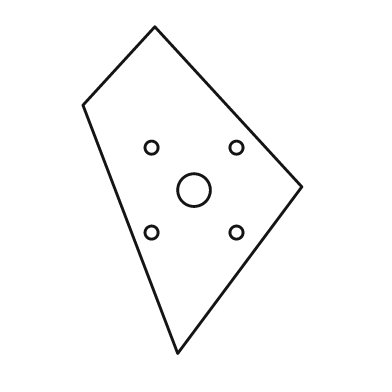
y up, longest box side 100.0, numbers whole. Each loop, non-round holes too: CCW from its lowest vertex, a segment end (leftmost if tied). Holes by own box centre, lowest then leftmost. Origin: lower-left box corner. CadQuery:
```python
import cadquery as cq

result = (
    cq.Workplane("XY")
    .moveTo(29.0, 0.0)
    .lineTo(67.0, 51.0)
    .lineTo(22.0, 100.0)
    .lineTo(0.0, 76.0)
    .close()
    .moveTo(21.0, 37.0)
    .circle(2.0)
    .moveTo(47.0, 37.0)
    .circle(2.0)
    .moveTo(34.0, 50.0)
    .circle(5.0)
    .moveTo(21.0, 63.0)
    .circle(2.0)
    .moveTo(47.0, 63.0)
    .circle(2.0)
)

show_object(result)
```